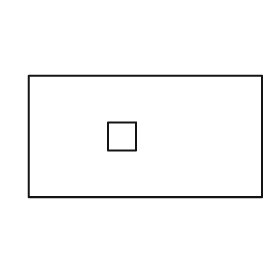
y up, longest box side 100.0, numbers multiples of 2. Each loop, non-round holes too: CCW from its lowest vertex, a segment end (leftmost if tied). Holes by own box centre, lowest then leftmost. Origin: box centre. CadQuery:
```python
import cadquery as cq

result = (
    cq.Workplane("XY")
    .moveTo(-50.0, -26.0)
    .lineTo(50.0, -26.0)
    .lineTo(50.0, 26.0)
    .lineTo(-50.0, 26.0)
    .close()
    .moveTo(-16.0, -6.0)
    .lineTo(-4.0, -6.0)
    .lineTo(-4.0, 6.0)
    .lineTo(-16.0, 6.0)
    .close()
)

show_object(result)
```